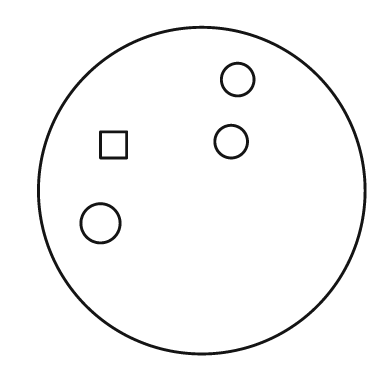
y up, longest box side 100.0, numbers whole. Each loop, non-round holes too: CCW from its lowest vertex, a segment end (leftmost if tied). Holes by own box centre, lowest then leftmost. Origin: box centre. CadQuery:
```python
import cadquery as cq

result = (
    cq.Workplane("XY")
    .moveTo(0.0, 0.0)
    .circle(50.0)
    .moveTo(-31.0, -10.0)
    .circle(6.0)
    .moveTo(-31.0, 10.0)
    .lineTo(-23.0, 10.0)
    .lineTo(-23.0, 18.0)
    .lineTo(-31.0, 18.0)
    .close()
    .moveTo(9.0, 15.0)
    .circle(5.0)
    .moveTo(11.0, 34.0)
    .circle(5.0)
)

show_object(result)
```